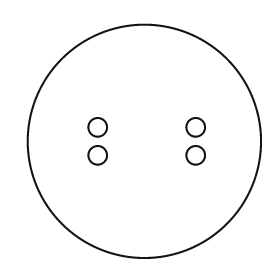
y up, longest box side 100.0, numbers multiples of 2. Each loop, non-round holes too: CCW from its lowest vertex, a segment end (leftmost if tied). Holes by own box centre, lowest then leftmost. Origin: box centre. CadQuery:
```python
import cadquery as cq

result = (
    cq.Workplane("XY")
    .moveTo(0.0, 0.0)
    .circle(50.0)
    .moveTo(-20.0, -6.0)
    .circle(4.0)
    .moveTo(22.0, -6.0)
    .circle(4.0)
    .moveTo(-20.0, 6.0)
    .circle(4.0)
    .moveTo(22.0, 6.0)
    .circle(4.0)
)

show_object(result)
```